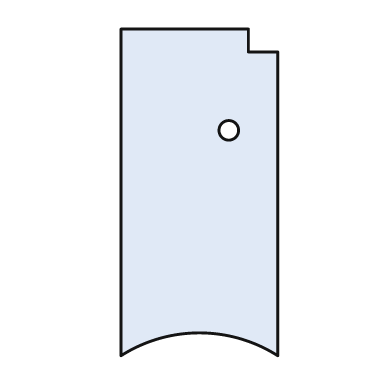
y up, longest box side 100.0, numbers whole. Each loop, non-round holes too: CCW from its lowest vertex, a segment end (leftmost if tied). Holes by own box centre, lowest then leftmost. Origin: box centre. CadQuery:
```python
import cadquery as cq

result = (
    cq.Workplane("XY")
    .moveTo(-24.0, -50.0)
    .threePointArc((0.0, -43.0), (24.0, -50.0))
    .lineTo(24.0, 43.0)
    .lineTo(15.0, 43.0)
    .lineTo(15.0, 50.0)
    .lineTo(-24.0, 50.0)
    .close()
    .moveTo(9.0, 19.0)
    .circle(3.0)
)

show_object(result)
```